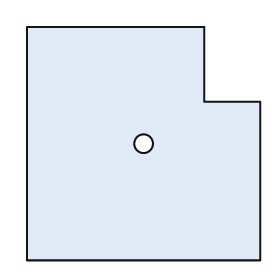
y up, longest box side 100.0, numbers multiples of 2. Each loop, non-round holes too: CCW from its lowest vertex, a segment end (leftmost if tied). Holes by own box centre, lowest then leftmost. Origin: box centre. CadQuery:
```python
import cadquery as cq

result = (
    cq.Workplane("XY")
    .moveTo(-50.0, -50.0)
    .lineTo(50.0, -50.0)
    .lineTo(50.0, 18.0)
    .lineTo(26.0, 18.0)
    .lineTo(26.0, 50.0)
    .lineTo(-50.0, 50.0)
    .close()
    .moveTo(0.0, 0.0)
    .circle(4.0)
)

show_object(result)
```